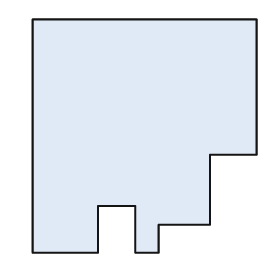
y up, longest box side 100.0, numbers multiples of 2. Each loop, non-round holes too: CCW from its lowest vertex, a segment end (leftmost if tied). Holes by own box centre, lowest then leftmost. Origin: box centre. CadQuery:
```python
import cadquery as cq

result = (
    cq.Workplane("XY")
    .moveTo(-48.0, -50.0)
    .lineTo(-20.0, -50.0)
    .lineTo(-20.0, -30.0)
    .lineTo(-4.0, -30.0)
    .lineTo(-4.0, -50.0)
    .lineTo(6.0, -50.0)
    .lineTo(6.0, -38.0)
    .lineTo(28.0, -38.0)
    .lineTo(28.0, -8.0)
    .lineTo(48.0, -8.0)
    .lineTo(48.0, 50.0)
    .lineTo(-48.0, 50.0)
    .close()
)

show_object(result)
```